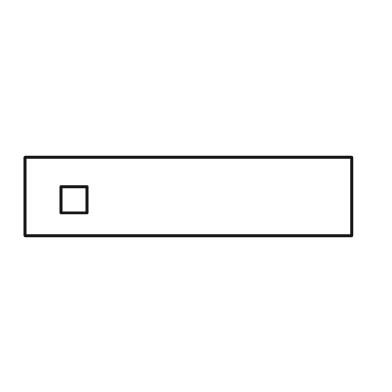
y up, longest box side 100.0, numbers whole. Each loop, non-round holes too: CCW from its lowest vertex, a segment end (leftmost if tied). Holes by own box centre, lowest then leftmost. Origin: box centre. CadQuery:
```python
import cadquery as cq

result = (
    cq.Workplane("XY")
    .moveTo(-50.0, -12.0)
    .lineTo(50.0, -12.0)
    .lineTo(50.0, 12.0)
    .lineTo(-50.0, 12.0)
    .close()
    .moveTo(-39.0, -5.0)
    .lineTo(-31.0, -5.0)
    .lineTo(-31.0, 3.0)
    .lineTo(-39.0, 3.0)
    .close()
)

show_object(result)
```